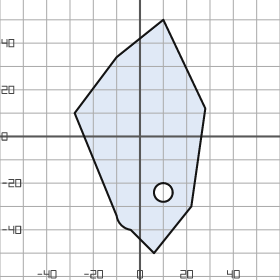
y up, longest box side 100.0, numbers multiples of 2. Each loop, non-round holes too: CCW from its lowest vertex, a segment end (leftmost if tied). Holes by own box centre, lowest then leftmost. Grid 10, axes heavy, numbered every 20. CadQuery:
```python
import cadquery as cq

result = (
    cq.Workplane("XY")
    .moveTo(6.0, -50.0)
    .lineTo(22.0, -30.0)
    .lineTo(28.0, 12.0)
    .lineTo(10.0, 50.0)
    .lineTo(-10.0, 34.0)
    .lineTo(-28.0, 10.0)
    .lineTo(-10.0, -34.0)
    .threePointArc((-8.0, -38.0), (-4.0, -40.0))
    .close()
    .moveTo(10.0, -24.0)
    .circle(4.0)
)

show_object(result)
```